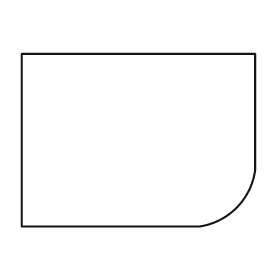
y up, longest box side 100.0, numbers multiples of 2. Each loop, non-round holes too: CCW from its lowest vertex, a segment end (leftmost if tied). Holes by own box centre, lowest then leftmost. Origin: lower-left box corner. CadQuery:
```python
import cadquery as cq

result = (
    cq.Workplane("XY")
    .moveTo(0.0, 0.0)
    .lineTo(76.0, 0.0)
    .threePointArc((92.0, 8.0), (100.0, 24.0))
    .lineTo(100.0, 74.0)
    .lineTo(0.0, 74.0)
    .close()
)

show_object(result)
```